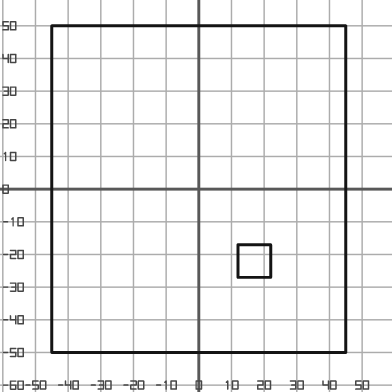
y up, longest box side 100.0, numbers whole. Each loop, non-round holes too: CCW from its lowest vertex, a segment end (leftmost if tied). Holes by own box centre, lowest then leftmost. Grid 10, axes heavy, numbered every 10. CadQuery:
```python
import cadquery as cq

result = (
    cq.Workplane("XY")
    .moveTo(-45.0, -50.0)
    .lineTo(45.0, -50.0)
    .lineTo(45.0, 50.0)
    .lineTo(-45.0, 50.0)
    .close()
    .moveTo(12.0, -27.0)
    .lineTo(22.0, -27.0)
    .lineTo(22.0, -17.0)
    .lineTo(12.0, -17.0)
    .close()
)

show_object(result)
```